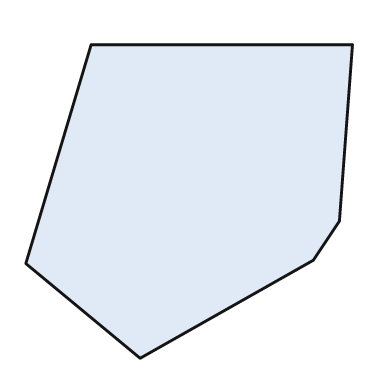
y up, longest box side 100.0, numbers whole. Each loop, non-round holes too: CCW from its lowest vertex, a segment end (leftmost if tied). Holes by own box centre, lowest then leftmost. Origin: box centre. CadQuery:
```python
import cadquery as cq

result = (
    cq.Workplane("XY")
    .moveTo(-15.0, -48.0)
    .lineTo(38.0, -18.0)
    .lineTo(46.0, -6.0)
    .lineTo(50.0, 48.0)
    .lineTo(-30.0, 48.0)
    .lineTo(-50.0, -19.0)
    .close()
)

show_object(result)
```